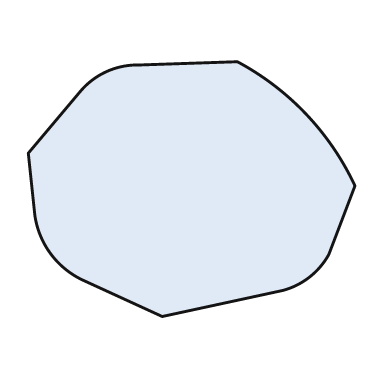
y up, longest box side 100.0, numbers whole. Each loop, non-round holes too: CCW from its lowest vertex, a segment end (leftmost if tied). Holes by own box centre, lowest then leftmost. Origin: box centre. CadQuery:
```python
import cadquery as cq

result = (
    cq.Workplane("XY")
    .moveTo(-9.0, -39.0)
    .lineTo(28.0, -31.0)
    .threePointArc((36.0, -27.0), (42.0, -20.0))
    .lineTo(50.0, 1.0)
    .threePointArc((35.0, 23.0), (14.0, 39.0))
    .lineTo(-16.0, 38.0)
    .threePointArc((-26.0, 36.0), (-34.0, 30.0))
    .lineTo(-50.0, 11.0)
    .lineTo(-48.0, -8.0)
    .threePointArc((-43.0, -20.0), (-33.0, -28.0))
    .close()
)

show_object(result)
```